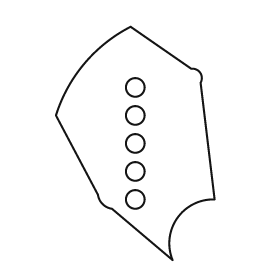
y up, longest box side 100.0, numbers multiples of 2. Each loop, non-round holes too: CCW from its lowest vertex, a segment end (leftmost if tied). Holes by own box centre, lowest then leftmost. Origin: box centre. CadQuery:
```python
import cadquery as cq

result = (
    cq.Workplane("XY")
    .moveTo(16.0, -50.0)
    .threePointArc((18.0, -32.0), (34.0, -24.0))
    .lineTo(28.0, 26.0)
    .threePointArc((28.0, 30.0), (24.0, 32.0))
    .lineTo(-2.0, 50.0)
    .threePointArc((-22.0, 34.0), (-34.0, 12.0))
    .lineTo(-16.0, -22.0)
    .threePointArc((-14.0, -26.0), (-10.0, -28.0))
    .close()
    .moveTo(0.0, -24.0)
    .circle(4.0)
    .moveTo(0.0, -12.0)
    .circle(4.0)
    .moveTo(0.0, 0.0)
    .circle(4.0)
    .moveTo(0.0, 12.0)
    .circle(4.0)
    .moveTo(0.0, 24.0)
    .circle(4.0)
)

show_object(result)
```